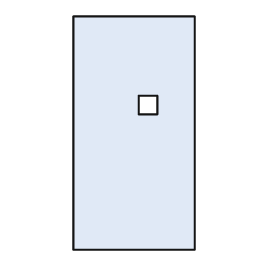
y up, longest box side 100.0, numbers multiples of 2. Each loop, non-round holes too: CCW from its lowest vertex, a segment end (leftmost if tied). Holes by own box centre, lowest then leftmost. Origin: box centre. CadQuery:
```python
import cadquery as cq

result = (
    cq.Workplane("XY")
    .moveTo(-26.0, -50.0)
    .lineTo(26.0, -50.0)
    .lineTo(26.0, 50.0)
    .lineTo(-26.0, 50.0)
    .close()
    .moveTo(2.0, 8.0)
    .lineTo(10.0, 8.0)
    .lineTo(10.0, 16.0)
    .lineTo(2.0, 16.0)
    .close()
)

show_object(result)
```